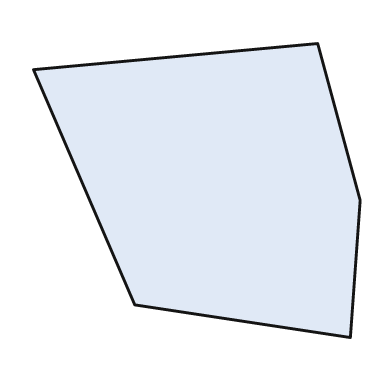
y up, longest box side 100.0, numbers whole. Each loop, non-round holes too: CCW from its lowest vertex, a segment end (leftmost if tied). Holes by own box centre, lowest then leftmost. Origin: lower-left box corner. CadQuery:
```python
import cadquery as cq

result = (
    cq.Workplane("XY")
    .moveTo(97.0, 0.0)
    .lineTo(100.0, 42.0)
    .lineTo(87.0, 90.0)
    .lineTo(0.0, 82.0)
    .lineTo(31.0, 10.0)
    .close()
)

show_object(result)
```